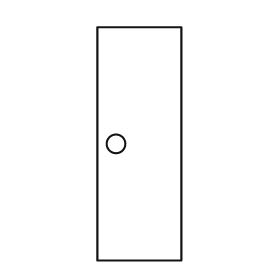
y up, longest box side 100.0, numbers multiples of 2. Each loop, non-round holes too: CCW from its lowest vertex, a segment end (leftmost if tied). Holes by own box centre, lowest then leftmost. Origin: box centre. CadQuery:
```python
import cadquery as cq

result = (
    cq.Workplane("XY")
    .moveTo(-18.0, -50.0)
    .lineTo(18.0, -50.0)
    .lineTo(18.0, 50.0)
    .lineTo(-18.0, 50.0)
    .close()
    .moveTo(-10.0, 0.0)
    .circle(4.0)
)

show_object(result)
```